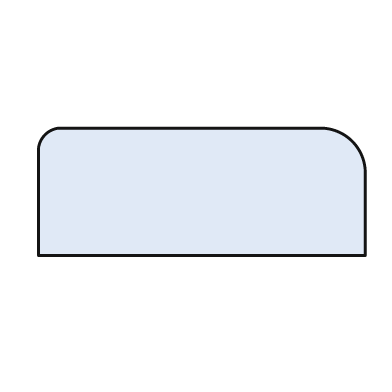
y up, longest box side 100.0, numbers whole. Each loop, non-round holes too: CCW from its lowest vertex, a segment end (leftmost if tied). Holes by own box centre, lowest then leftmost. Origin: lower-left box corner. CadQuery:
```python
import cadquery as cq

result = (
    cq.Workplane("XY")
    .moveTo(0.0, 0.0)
    .lineTo(100.0, 0.0)
    .lineTo(100.0, 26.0)
    .threePointArc((96.0, 35.0), (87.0, 39.0))
    .lineTo(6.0, 39.0)
    .threePointArc((2.0, 37.0), (0.0, 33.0))
    .close()
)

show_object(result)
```